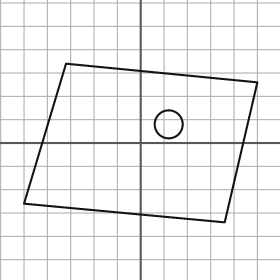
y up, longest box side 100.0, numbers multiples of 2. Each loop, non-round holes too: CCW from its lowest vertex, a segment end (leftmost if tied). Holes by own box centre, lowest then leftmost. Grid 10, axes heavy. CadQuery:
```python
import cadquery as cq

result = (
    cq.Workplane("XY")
    .moveTo(36.0, -34.0)
    .lineTo(50.0, 26.0)
    .lineTo(-32.0, 34.0)
    .lineTo(-50.0, -26.0)
    .close()
    .moveTo(12.0, 8.0)
    .circle(6.0)
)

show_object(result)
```